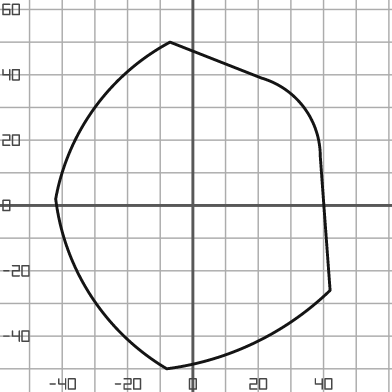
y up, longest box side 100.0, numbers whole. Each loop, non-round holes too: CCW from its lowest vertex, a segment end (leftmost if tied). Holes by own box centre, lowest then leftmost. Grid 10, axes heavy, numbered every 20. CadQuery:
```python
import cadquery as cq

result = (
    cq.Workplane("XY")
    .moveTo(-8.0, -50.0)
    .threePointArc((19.0, -42.0), (42.0, -26.0))
    .lineTo(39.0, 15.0)
    .threePointArc((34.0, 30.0), (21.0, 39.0))
    .lineTo(-7.0, 50.0)
    .threePointArc((-30.0, 30.0), (-42.0, 2.0))
    .threePointArc((-31.0, -28.0), (-8.0, -50.0))
    .close()
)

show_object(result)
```